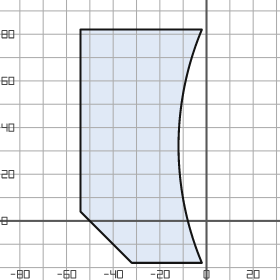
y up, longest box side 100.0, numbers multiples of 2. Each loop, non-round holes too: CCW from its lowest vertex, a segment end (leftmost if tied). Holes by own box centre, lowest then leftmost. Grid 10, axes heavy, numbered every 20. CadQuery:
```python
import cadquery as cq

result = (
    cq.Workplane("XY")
    .moveTo(-32.0, -18.0)
    .lineTo(-2.0, -18.0)
    .threePointArc((-12.0, 32.0), (-2.0, 82.0))
    .lineTo(-54.0, 82.0)
    .lineTo(-54.0, 4.0)
    .close()
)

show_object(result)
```